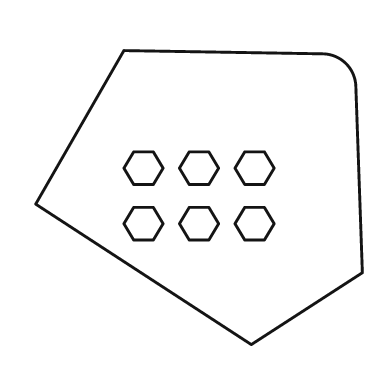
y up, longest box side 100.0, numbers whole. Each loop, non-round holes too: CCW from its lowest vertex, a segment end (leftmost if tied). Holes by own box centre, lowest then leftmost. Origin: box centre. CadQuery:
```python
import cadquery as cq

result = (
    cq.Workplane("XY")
    .moveTo(16.0, -45.0)
    .lineTo(50.0, -23.0)
    .lineTo(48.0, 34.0)
    .threePointArc((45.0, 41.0), (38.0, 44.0))
    .lineTo(-23.0, 45.0)
    .lineTo(-50.0, -2.0)
    .close()
    .moveTo(-20.0, -13.0)
    .lineTo(-14.0, -13.0)
    .lineTo(-11.0, -8.0)
    .lineTo(-14.0, -3.0)
    .lineTo(-20.0, -3.0)
    .lineTo(-23.0, -8.0)
    .close()
    .moveTo(-3.0, -13.0)
    .lineTo(3.0, -13.0)
    .lineTo(6.0, -8.0)
    .lineTo(3.0, -3.0)
    .lineTo(-3.0, -3.0)
    .lineTo(-6.0, -8.0)
    .close()
    .moveTo(14.0, -13.0)
    .lineTo(20.0, -13.0)
    .lineTo(23.0, -8.0)
    .lineTo(20.0, -3.0)
    .lineTo(14.0, -3.0)
    .lineTo(11.0, -8.0)
    .close()
    .moveTo(-20.0, 4.0)
    .lineTo(-14.0, 4.0)
    .lineTo(-11.0, 9.0)
    .lineTo(-14.0, 14.0)
    .lineTo(-20.0, 14.0)
    .lineTo(-23.0, 9.0)
    .close()
    .moveTo(-3.0, 4.0)
    .lineTo(3.0, 4.0)
    .lineTo(6.0, 9.0)
    .lineTo(3.0, 14.0)
    .lineTo(-3.0, 14.0)
    .lineTo(-6.0, 9.0)
    .close()
    .moveTo(14.0, 4.0)
    .lineTo(20.0, 4.0)
    .lineTo(23.0, 9.0)
    .lineTo(20.0, 14.0)
    .lineTo(14.0, 14.0)
    .lineTo(11.0, 9.0)
    .close()
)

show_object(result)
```